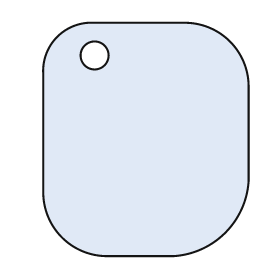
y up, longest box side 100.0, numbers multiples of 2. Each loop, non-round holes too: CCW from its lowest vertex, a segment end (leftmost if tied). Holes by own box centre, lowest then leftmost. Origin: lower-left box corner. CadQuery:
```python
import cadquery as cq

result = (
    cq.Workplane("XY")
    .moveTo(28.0, 0.0)
    .lineTo(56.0, 0.0)
    .threePointArc((78.0, 10.0), (88.0, 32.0))
    .lineTo(88.0, 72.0)
    .threePointArc((80.0, 92.0), (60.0, 100.0))
    .lineTo(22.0, 100.0)
    .threePointArc((6.0, 94.0), (0.0, 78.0))
    .lineTo(0.0, 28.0)
    .threePointArc((8.0, 8.0), (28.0, 0.0))
    .close()
    .moveTo(22.0, 86.0)
    .circle(6.0)
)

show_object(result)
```